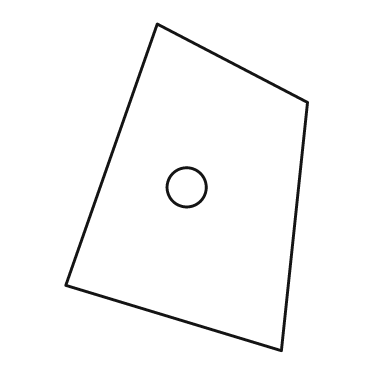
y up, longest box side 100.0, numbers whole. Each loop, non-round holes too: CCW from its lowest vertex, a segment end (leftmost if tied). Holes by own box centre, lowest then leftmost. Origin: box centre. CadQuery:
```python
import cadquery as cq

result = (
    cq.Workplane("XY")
    .moveTo(29.0, -50.0)
    .lineTo(37.0, 26.0)
    .lineTo(-9.0, 50.0)
    .lineTo(-37.0, -30.0)
    .close()
    .moveTo(0.0, 0.0)
    .circle(6.0)
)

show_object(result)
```